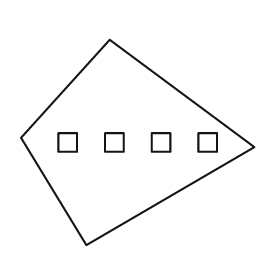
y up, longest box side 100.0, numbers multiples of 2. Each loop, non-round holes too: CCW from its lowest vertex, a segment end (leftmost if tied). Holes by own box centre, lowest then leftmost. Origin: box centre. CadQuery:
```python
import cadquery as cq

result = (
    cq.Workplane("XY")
    .moveTo(-22.0, -44.0)
    .lineTo(50.0, -2.0)
    .lineTo(-12.0, 44.0)
    .lineTo(-50.0, 2.0)
    .close()
    .moveTo(-34.0, -4.0)
    .lineTo(-26.0, -4.0)
    .lineTo(-26.0, 4.0)
    .lineTo(-34.0, 4.0)
    .close()
    .moveTo(-14.0, -4.0)
    .lineTo(-6.0, -4.0)
    .lineTo(-6.0, 4.0)
    .lineTo(-14.0, 4.0)
    .close()
    .moveTo(6.0, -4.0)
    .lineTo(14.0, -4.0)
    .lineTo(14.0, 4.0)
    .lineTo(6.0, 4.0)
    .close()
    .moveTo(26.0, -4.0)
    .lineTo(34.0, -4.0)
    .lineTo(34.0, 4.0)
    .lineTo(26.0, 4.0)
    .close()
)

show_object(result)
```